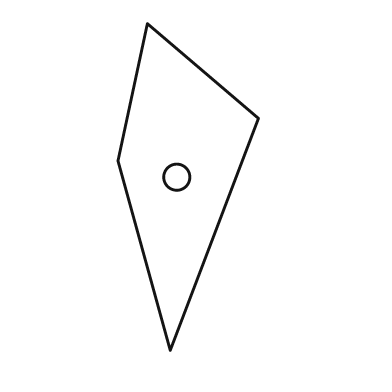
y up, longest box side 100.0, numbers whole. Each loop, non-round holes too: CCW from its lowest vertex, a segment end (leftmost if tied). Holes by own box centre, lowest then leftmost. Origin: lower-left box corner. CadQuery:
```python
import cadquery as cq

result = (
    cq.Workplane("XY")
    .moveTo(16.0, 0.0)
    .lineTo(43.0, 71.0)
    .lineTo(9.0, 100.0)
    .lineTo(0.0, 58.0)
    .close()
    .moveTo(18.0, 53.0)
    .circle(4.0)
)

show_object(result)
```